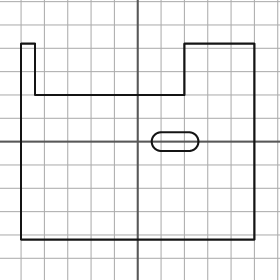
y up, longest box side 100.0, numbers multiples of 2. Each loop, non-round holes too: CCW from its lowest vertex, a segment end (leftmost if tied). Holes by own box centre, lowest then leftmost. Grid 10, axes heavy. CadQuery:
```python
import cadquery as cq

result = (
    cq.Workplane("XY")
    .moveTo(-50.0, -42.0)
    .lineTo(50.0, -42.0)
    .lineTo(50.0, 42.0)
    .lineTo(20.0, 42.0)
    .lineTo(20.0, 20.0)
    .lineTo(-44.0, 20.0)
    .lineTo(-44.0, 42.0)
    .lineTo(-50.0, 42.0)
    .close()
    .moveTo(10.0, -4.0)
    .lineTo(22.0, -4.0)
    .threePointArc((26.0, 0.0), (22.0, 4.0))
    .lineTo(10.0, 4.0)
    .threePointArc((6.0, 0.0), (10.0, -4.0))
    .close()
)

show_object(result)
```